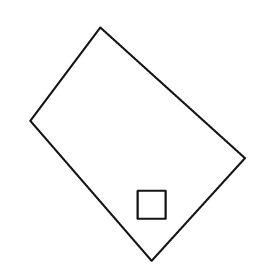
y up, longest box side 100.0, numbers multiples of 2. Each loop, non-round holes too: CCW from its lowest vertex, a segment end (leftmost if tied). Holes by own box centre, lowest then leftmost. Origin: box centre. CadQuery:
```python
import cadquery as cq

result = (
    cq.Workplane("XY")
    .moveTo(6.0, -50.0)
    .lineTo(46.0, -6.0)
    .lineTo(-16.0, 50.0)
    .lineTo(-46.0, 10.0)
    .close()
    .moveTo(0.0, -32.0)
    .lineTo(12.0, -32.0)
    .lineTo(12.0, -20.0)
    .lineTo(0.0, -20.0)
    .close()
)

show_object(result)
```